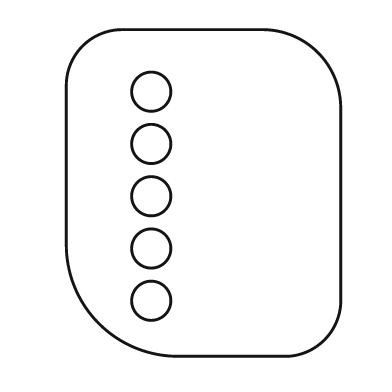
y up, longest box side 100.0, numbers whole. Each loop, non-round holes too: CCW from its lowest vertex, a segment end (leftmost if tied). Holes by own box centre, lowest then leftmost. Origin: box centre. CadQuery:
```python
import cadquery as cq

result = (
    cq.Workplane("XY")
    .moveTo(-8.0, -50.0)
    .lineTo(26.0, -50.0)
    .threePointArc((37.0, -45.0), (42.0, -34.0))
    .lineTo(42.0, 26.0)
    .threePointArc((35.0, 43.0), (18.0, 50.0))
    .lineTo(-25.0, 50.0)
    .threePointArc((-37.0, 45.0), (-42.0, 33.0))
    .lineTo(-42.0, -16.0)
    .threePointArc((-32.0, -40.0), (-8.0, -50.0))
    .close()
    .moveTo(-16.0, -33.0)
    .circle(6.0)
    .moveTo(-16.0, -17.0)
    .circle(6.0)
    .moveTo(-16.0, -1.0)
    .circle(6.0)
    .moveTo(-16.0, 15.0)
    .circle(6.0)
    .moveTo(-16.0, 31.0)
    .circle(6.0)
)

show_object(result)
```